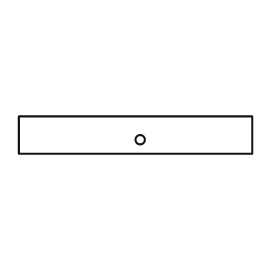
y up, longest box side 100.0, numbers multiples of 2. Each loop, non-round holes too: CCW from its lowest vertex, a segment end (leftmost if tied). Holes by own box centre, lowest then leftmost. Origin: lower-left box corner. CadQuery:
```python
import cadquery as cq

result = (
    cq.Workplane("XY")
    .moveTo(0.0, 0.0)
    .lineTo(100.0, 0.0)
    .lineTo(100.0, 16.0)
    .lineTo(0.0, 16.0)
    .close()
    .moveTo(52.0, 6.0)
    .circle(2.0)
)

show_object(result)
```